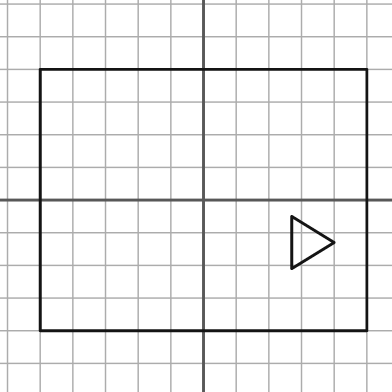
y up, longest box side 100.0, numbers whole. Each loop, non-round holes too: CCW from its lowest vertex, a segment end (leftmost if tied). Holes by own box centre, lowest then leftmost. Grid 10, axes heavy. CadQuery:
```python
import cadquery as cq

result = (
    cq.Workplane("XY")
    .moveTo(-50.0, -40.0)
    .lineTo(50.0, -40.0)
    .lineTo(50.0, 40.0)
    .lineTo(-50.0, 40.0)
    .close()
    .moveTo(27.0, -21.0)
    .lineTo(40.0, -13.0)
    .lineTo(27.0, -5.0)
    .close()
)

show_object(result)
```